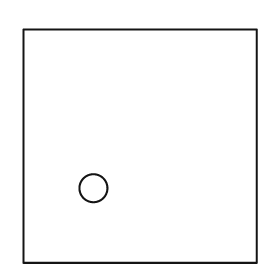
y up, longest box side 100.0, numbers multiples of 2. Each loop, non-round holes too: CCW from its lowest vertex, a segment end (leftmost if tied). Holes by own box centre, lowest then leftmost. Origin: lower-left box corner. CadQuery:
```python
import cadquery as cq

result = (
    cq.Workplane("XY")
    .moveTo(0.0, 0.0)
    .lineTo(100.0, 0.0)
    .lineTo(100.0, 100.0)
    .lineTo(0.0, 100.0)
    .close()
    .moveTo(30.0, 32.0)
    .circle(6.0)
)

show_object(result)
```